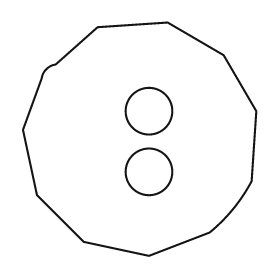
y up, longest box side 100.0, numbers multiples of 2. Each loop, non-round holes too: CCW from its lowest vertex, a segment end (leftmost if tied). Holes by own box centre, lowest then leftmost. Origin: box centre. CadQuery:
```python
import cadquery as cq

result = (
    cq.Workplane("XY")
    .moveTo(4.0, -50.0)
    .lineTo(30.0, -40.0)
    .threePointArc((40.0, -30.0), (48.0, -18.0))
    .lineTo(50.0, 12.0)
    .lineTo(36.0, 36.0)
    .lineTo(12.0, 50.0)
    .lineTo(-18.0, 48.0)
    .lineTo(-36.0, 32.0)
    .threePointArc((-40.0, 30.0), (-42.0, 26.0))
    .lineTo(-50.0, 4.0)
    .lineTo(-44.0, -24.0)
    .lineTo(-24.0, -44.0)
    .close()
    .moveTo(4.0, -14.0)
    .circle(10.0)
    .moveTo(4.0, 12.0)
    .circle(10.0)
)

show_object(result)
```